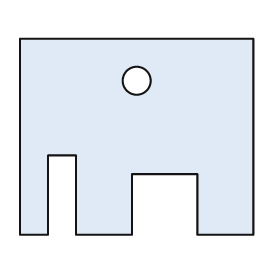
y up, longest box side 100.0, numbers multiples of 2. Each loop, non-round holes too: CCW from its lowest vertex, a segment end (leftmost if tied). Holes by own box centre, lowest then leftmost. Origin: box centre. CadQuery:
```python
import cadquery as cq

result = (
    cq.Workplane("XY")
    .moveTo(-50.0, -42.0)
    .lineTo(-38.0, -42.0)
    .lineTo(-38.0, -8.0)
    .lineTo(-26.0, -8.0)
    .lineTo(-26.0, -42.0)
    .lineTo(-2.0, -42.0)
    .lineTo(-2.0, -16.0)
    .lineTo(26.0, -16.0)
    .lineTo(26.0, -42.0)
    .lineTo(50.0, -42.0)
    .lineTo(50.0, 42.0)
    .lineTo(-50.0, 42.0)
    .close()
    .moveTo(0.0, 24.0)
    .circle(6.0)
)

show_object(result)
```